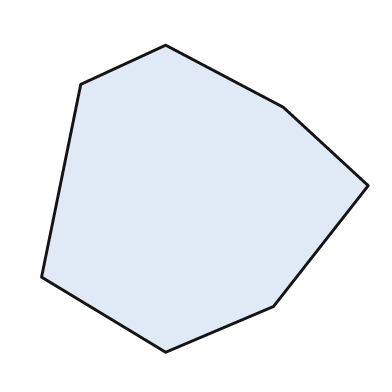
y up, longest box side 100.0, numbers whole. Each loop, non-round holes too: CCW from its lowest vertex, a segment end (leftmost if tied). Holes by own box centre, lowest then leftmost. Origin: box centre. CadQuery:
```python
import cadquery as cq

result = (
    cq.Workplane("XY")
    .moveTo(-12.0, -47.0)
    .lineTo(21.0, -33.0)
    .lineTo(50.0, 4.0)
    .lineTo(24.0, 28.0)
    .lineTo(-12.0, 47.0)
    .lineTo(-38.0, 35.0)
    .lineTo(-50.0, -24.0)
    .close()
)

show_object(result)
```